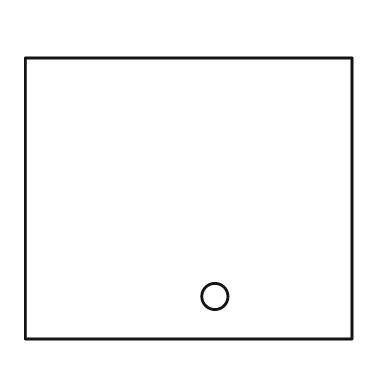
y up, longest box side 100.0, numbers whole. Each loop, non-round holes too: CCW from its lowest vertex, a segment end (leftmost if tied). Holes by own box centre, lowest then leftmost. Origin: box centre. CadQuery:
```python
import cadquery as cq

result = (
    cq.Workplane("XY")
    .moveTo(-50.0, -43.0)
    .lineTo(50.0, -43.0)
    .lineTo(50.0, 43.0)
    .lineTo(-50.0, 43.0)
    .close()
    .moveTo(8.0, -30.0)
    .circle(4.0)
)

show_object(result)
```